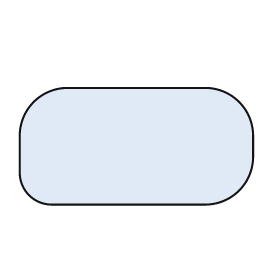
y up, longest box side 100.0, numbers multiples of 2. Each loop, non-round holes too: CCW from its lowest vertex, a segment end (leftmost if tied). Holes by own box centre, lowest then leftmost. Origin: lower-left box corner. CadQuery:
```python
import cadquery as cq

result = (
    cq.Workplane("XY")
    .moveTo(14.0, 0.0)
    .lineTo(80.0, 0.0)
    .threePointArc((94.0, 6.0), (100.0, 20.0))
    .lineTo(100.0, 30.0)
    .threePointArc((94.0, 44.0), (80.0, 50.0))
    .lineTo(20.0, 50.0)
    .threePointArc((6.0, 44.0), (0.0, 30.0))
    .lineTo(0.0, 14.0)
    .threePointArc((4.0, 4.0), (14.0, 0.0))
    .close()
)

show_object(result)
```